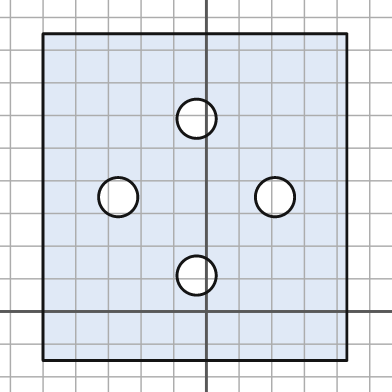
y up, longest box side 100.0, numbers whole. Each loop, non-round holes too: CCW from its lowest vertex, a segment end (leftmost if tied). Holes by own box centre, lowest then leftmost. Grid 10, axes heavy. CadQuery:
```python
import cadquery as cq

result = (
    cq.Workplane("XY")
    .moveTo(-50.0, -15.0)
    .lineTo(43.0, -15.0)
    .lineTo(43.0, 85.0)
    .lineTo(-50.0, 85.0)
    .close()
    .moveTo(-3.0, 11.0)
    .circle(6.0)
    .moveTo(-27.0, 35.0)
    .circle(6.0)
    .moveTo(21.0, 35.0)
    .circle(6.0)
    .moveTo(-3.0, 59.0)
    .circle(6.0)
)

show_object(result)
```